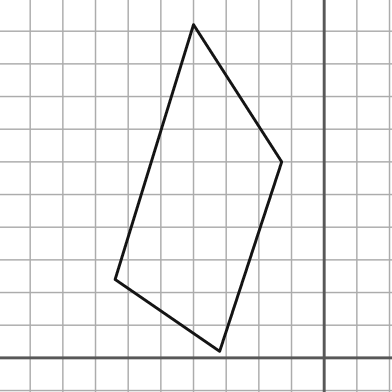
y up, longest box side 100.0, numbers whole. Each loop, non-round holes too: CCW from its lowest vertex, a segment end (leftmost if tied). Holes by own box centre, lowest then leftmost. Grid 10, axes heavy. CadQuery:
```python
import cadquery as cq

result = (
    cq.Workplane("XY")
    .moveTo(-32.0, 2.0)
    .lineTo(-13.0, 60.0)
    .lineTo(-40.0, 102.0)
    .lineTo(-64.0, 24.0)
    .close()
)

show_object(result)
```